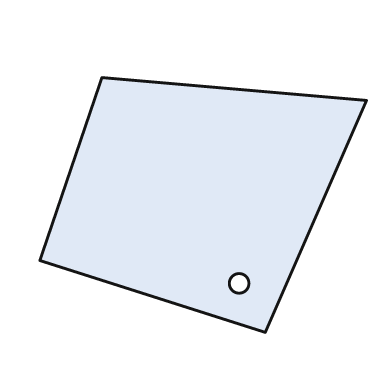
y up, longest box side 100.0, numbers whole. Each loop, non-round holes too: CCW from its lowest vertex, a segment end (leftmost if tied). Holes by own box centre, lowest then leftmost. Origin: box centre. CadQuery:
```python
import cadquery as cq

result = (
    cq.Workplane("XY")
    .moveTo(19.0, -39.0)
    .lineTo(50.0, 32.0)
    .lineTo(-31.0, 39.0)
    .lineTo(-50.0, -17.0)
    .close()
    .moveTo(11.0, -24.0)
    .circle(3.0)
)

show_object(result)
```